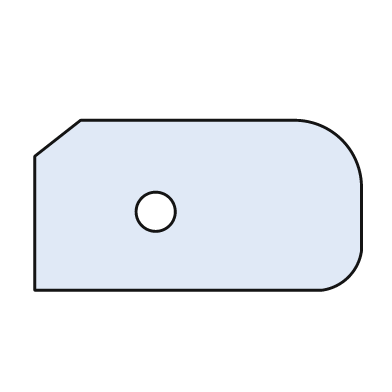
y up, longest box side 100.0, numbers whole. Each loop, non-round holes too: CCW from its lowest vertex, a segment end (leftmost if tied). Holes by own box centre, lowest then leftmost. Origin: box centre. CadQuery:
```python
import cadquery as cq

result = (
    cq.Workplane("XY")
    .moveTo(-50.0, -26.0)
    .lineTo(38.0, -26.0)
    .threePointArc((46.0, -22.0), (50.0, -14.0))
    .lineTo(50.0, 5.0)
    .threePointArc((44.0, 20.0), (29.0, 26.0))
    .lineTo(-36.0, 26.0)
    .lineTo(-50.0, 15.0)
    .close()
    .moveTo(-13.0, -2.0)
    .circle(6.0)
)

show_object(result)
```